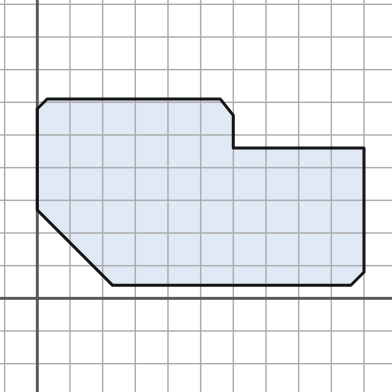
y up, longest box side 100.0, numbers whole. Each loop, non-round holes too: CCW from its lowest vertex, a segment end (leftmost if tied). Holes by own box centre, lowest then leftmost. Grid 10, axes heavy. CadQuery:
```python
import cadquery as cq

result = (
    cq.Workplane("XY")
    .moveTo(23.0, 4.0)
    .lineTo(96.0, 4.0)
    .lineTo(100.0, 8.0)
    .lineTo(100.0, 46.0)
    .lineTo(60.0, 46.0)
    .lineTo(60.0, 56.0)
    .lineTo(56.0, 61.0)
    .lineTo(3.0, 61.0)
    .lineTo(0.0, 58.0)
    .lineTo(0.0, 27.0)
    .close()
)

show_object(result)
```